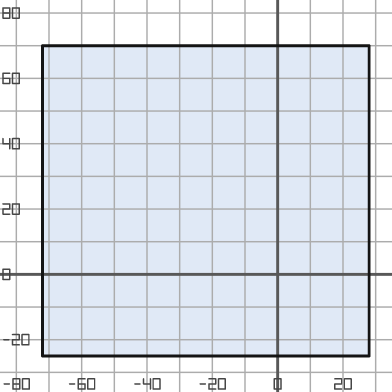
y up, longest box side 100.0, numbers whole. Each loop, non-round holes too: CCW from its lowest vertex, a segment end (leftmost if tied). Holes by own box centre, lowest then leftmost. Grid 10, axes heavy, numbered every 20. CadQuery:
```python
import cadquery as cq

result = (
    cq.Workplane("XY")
    .moveTo(-72.0, -25.0)
    .lineTo(28.0, -25.0)
    .lineTo(28.0, 70.0)
    .lineTo(-72.0, 70.0)
    .close()
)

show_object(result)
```